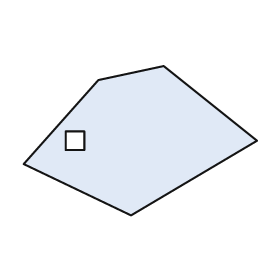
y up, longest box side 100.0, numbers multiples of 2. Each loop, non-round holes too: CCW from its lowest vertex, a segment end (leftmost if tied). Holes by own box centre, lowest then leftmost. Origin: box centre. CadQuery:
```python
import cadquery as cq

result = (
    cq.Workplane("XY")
    .moveTo(-4.0, -32.0)
    .lineTo(50.0, 0.0)
    .lineTo(10.0, 32.0)
    .lineTo(-18.0, 26.0)
    .lineTo(-50.0, -10.0)
    .close()
    .moveTo(-32.0, -4.0)
    .lineTo(-24.0, -4.0)
    .lineTo(-24.0, 4.0)
    .lineTo(-32.0, 4.0)
    .close()
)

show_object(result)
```